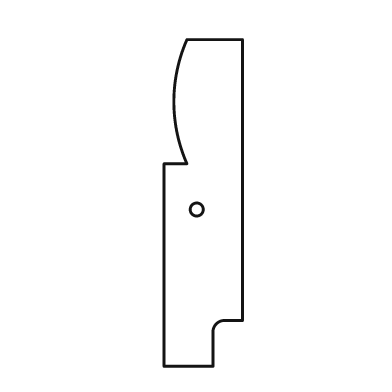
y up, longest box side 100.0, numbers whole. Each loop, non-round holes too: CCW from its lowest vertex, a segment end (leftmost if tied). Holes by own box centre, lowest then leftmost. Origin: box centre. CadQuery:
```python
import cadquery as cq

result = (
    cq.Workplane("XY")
    .moveTo(-12.0, -50.0)
    .lineTo(3.0, -50.0)
    .lineTo(3.0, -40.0)
    .threePointArc((4.0, -37.0), (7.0, -36.0))
    .lineTo(12.0, -36.0)
    .lineTo(12.0, 50.0)
    .lineTo(-5.0, 50.0)
    .threePointArc((-9.0, 31.0), (-5.0, 12.0))
    .lineTo(-12.0, 12.0)
    .close()
    .moveTo(-2.0, -2.0)
    .circle(2.0)
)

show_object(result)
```